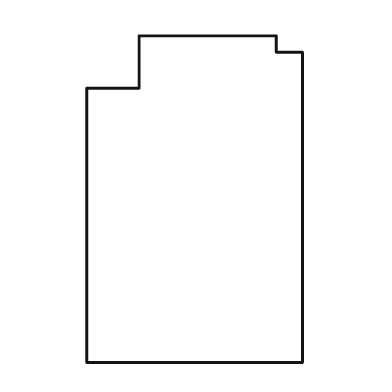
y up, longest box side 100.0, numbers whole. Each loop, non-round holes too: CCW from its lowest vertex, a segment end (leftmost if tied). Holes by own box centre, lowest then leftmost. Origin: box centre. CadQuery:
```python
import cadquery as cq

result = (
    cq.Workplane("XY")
    .moveTo(-33.0, -50.0)
    .lineTo(33.0, -50.0)
    .lineTo(33.0, 45.0)
    .lineTo(25.0, 45.0)
    .lineTo(25.0, 50.0)
    .lineTo(-17.0, 50.0)
    .lineTo(-17.0, 34.0)
    .lineTo(-33.0, 34.0)
    .close()
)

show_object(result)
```